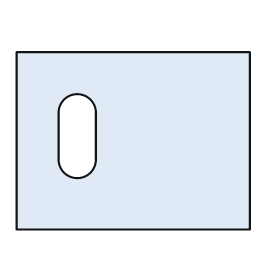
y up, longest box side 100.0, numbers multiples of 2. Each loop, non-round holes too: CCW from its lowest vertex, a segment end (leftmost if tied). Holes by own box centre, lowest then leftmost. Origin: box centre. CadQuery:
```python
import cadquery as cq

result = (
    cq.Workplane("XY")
    .moveTo(-50.0, -38.0)
    .lineTo(50.0, -38.0)
    .lineTo(50.0, 38.0)
    .lineTo(-50.0, 38.0)
    .close()
    .moveTo(-32.0, -8.0)
    .threePointArc((-24.0, -16.0), (-16.0, -8.0))
    .lineTo(-16.0, 12.0)
    .threePointArc((-24.0, 20.0), (-32.0, 12.0))
    .close()
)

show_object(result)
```